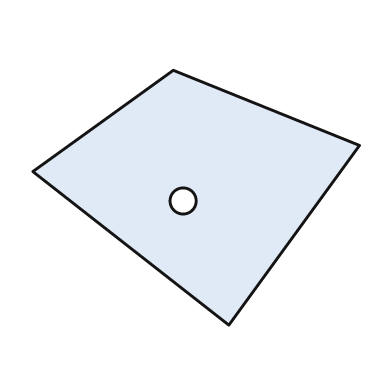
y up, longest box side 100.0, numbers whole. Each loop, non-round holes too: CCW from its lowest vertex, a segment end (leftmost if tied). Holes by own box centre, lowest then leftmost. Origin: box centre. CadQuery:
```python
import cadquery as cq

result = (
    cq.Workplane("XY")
    .moveTo(10.0, -39.0)
    .lineTo(50.0, 16.0)
    .lineTo(-7.0, 39.0)
    .lineTo(-50.0, 8.0)
    .close()
    .moveTo(-4.0, -1.0)
    .circle(4.0)
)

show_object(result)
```